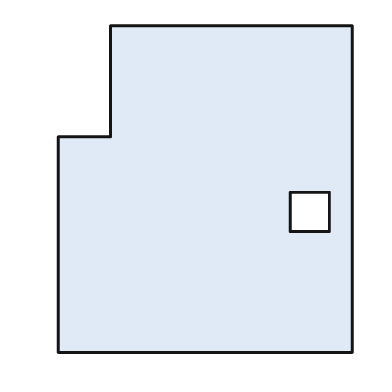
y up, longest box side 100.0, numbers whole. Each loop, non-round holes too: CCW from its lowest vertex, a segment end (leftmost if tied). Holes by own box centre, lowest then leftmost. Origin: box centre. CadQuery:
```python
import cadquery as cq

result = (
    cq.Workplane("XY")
    .moveTo(-45.0, -50.0)
    .lineTo(45.0, -50.0)
    .lineTo(45.0, 50.0)
    .lineTo(-29.0, 50.0)
    .lineTo(-29.0, 16.0)
    .lineTo(-45.0, 16.0)
    .close()
    .moveTo(26.0, -13.0)
    .lineTo(38.0, -13.0)
    .lineTo(38.0, -1.0)
    .lineTo(26.0, -1.0)
    .close()
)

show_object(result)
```